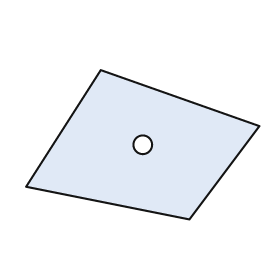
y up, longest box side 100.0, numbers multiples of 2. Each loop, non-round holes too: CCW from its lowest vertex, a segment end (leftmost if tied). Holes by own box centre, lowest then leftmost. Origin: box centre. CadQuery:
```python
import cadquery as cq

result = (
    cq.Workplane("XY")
    .moveTo(20.0, -32.0)
    .lineTo(50.0, 8.0)
    .lineTo(-18.0, 32.0)
    .lineTo(-50.0, -18.0)
    .close()
    .moveTo(0.0, 0.0)
    .circle(4.0)
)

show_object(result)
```